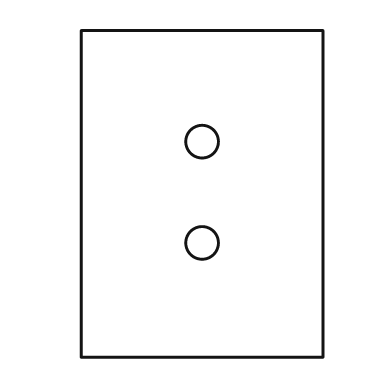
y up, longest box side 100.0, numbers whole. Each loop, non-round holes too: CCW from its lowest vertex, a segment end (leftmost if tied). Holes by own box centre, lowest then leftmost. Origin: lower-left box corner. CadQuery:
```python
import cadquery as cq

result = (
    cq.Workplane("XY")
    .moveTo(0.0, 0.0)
    .lineTo(74.0, 0.0)
    .lineTo(74.0, 100.0)
    .lineTo(0.0, 100.0)
    .close()
    .moveTo(37.0, 35.0)
    .circle(5.0)
    .moveTo(37.0, 66.0)
    .circle(5.0)
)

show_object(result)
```